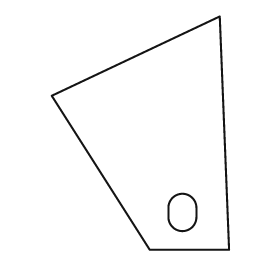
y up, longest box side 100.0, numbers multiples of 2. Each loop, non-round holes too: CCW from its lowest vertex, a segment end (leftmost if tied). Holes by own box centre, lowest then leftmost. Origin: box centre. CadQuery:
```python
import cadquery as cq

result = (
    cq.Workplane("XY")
    .moveTo(4.0, -50.0)
    .lineTo(38.0, -50.0)
    .lineTo(34.0, 50.0)
    .lineTo(-38.0, 16.0)
    .close()
    .moveTo(12.0, -36.0)
    .threePointArc((18.0, -42.0), (24.0, -36.0))
    .lineTo(24.0, -32.0)
    .threePointArc((18.0, -26.0), (12.0, -32.0))
    .close()
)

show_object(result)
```